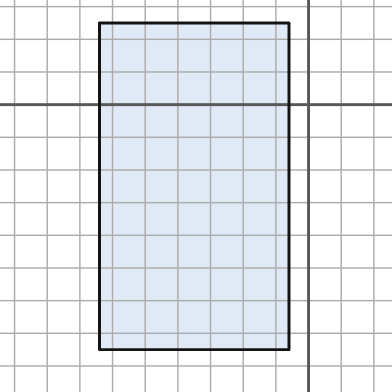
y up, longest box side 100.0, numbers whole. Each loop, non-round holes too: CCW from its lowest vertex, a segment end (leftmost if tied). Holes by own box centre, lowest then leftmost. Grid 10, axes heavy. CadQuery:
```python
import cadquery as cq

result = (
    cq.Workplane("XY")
    .moveTo(-64.0, -75.0)
    .lineTo(-6.0, -75.0)
    .lineTo(-6.0, 25.0)
    .lineTo(-64.0, 25.0)
    .close()
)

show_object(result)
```